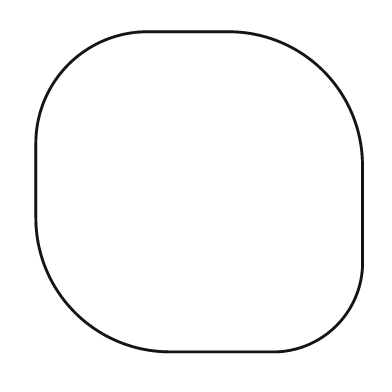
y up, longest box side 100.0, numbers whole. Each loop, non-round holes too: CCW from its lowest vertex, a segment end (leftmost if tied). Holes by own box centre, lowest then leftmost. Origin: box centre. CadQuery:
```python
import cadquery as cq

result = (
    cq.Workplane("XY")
    .moveTo(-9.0, -49.0)
    .lineTo(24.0, -49.0)
    .threePointArc((42.0, -41.0), (50.0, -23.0))
    .lineTo(50.0, 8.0)
    .threePointArc((38.0, 37.0), (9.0, 49.0))
    .lineTo(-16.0, 49.0)
    .threePointArc((-40.0, 39.0), (-50.0, 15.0))
    .lineTo(-50.0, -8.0)
    .threePointArc((-38.0, -37.0), (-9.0, -49.0))
    .close()
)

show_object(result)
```